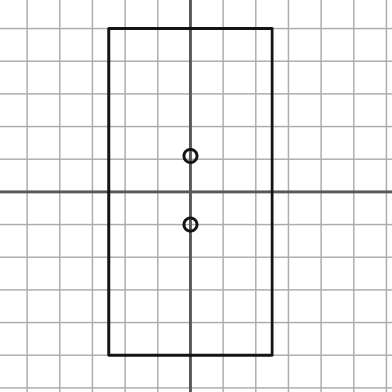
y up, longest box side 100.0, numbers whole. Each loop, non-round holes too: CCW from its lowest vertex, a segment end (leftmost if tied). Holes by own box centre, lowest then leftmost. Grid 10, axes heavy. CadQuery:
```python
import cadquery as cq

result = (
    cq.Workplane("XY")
    .moveTo(-25.0, -50.0)
    .lineTo(25.0, -50.0)
    .lineTo(25.0, 50.0)
    .lineTo(-25.0, 50.0)
    .close()
    .moveTo(0.0, -10.0)
    .circle(2.0)
    .moveTo(0.0, 11.0)
    .circle(2.0)
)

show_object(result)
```